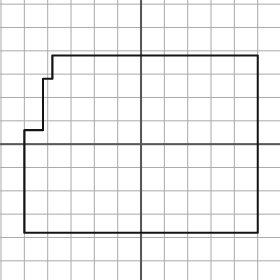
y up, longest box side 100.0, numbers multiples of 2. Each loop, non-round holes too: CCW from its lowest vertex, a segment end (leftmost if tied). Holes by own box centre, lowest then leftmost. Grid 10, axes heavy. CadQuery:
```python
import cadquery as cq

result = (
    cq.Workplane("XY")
    .moveTo(-50.0, -38.0)
    .lineTo(50.0, -38.0)
    .lineTo(50.0, 38.0)
    .lineTo(-38.0, 38.0)
    .lineTo(-38.0, 28.0)
    .lineTo(-42.0, 28.0)
    .lineTo(-42.0, 6.0)
    .lineTo(-50.0, 6.0)
    .close()
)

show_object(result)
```